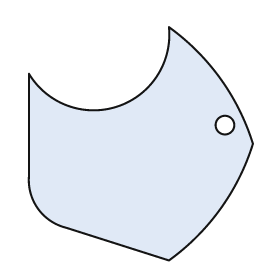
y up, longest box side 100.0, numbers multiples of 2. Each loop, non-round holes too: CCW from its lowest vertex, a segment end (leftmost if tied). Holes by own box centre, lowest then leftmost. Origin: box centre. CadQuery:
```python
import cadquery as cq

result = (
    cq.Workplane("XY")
    .moveTo(12.0, -50.0)
    .threePointArc((34.0, -28.0), (48.0, 0.0))
    .threePointArc((34.0, 28.0), (12.0, 50.0))
    .threePointArc((-10.0, 16.0), (-48.0, 30.0))
    .lineTo(-48.0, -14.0)
    .threePointArc((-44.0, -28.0), (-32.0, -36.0))
    .close()
    .moveTo(36.0, 8.0)
    .circle(4.0)
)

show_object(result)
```